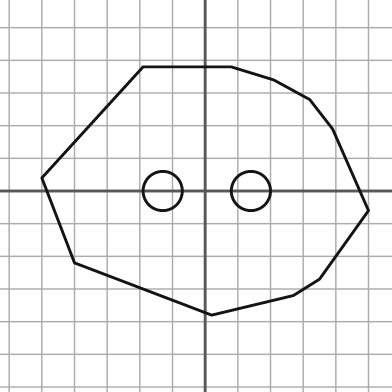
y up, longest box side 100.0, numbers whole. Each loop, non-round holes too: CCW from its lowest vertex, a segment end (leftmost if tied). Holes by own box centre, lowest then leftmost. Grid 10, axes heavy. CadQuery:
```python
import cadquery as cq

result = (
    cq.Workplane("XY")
    .moveTo(2.0, -38.0)
    .lineTo(27.0, -32.0)
    .lineTo(35.0, -27.0)
    .lineTo(50.0, -6.0)
    .lineTo(39.0, 19.0)
    .lineTo(32.0, 28.0)
    .lineTo(21.0, 34.0)
    .lineTo(8.0, 38.0)
    .lineTo(-19.0, 38.0)
    .lineTo(-50.0, 4.0)
    .lineTo(-40.0, -22.0)
    .close()
    .moveTo(-13.0, 0.0)
    .circle(6.0)
    .moveTo(14.0, 0.0)
    .circle(6.0)
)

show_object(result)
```